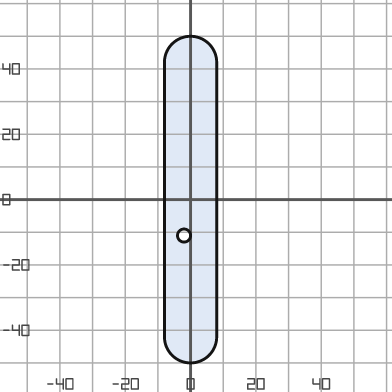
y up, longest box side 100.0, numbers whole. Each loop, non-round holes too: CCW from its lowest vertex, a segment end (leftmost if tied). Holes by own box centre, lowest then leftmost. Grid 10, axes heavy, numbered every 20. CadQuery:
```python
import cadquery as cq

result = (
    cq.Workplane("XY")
    .moveTo(-8.0, -42.0)
    .threePointArc((0.0, -50.0), (8.0, -42.0))
    .lineTo(8.0, 42.0)
    .threePointArc((0.0, 50.0), (-8.0, 42.0))
    .close()
    .moveTo(-2.0, -11.0)
    .circle(2.0)
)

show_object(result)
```